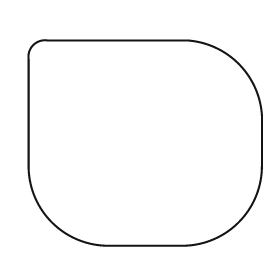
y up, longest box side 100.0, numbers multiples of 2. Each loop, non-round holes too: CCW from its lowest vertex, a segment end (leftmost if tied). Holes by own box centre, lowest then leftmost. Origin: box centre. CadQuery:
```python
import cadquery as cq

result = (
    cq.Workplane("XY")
    .moveTo(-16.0, -44.0)
    .lineTo(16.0, -44.0)
    .threePointArc((40.0, -34.0), (50.0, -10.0))
    .lineTo(50.0, 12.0)
    .threePointArc((40.0, 34.0), (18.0, 44.0))
    .lineTo(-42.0, 44.0)
    .threePointArc((-48.0, 42.0), (-50.0, 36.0))
    .lineTo(-50.0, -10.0)
    .threePointArc((-40.0, -34.0), (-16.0, -44.0))
    .close()
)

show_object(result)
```